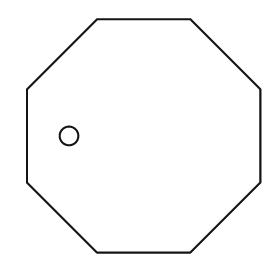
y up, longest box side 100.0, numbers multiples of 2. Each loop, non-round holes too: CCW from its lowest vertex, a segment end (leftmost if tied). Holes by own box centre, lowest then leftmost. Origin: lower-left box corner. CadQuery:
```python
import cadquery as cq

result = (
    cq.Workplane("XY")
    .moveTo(30.0, 0.0)
    .lineTo(70.0, 0.0)
    .lineTo(100.0, 30.0)
    .lineTo(100.0, 70.0)
    .lineTo(70.0, 100.0)
    .lineTo(30.0, 100.0)
    .lineTo(0.0, 70.0)
    .lineTo(0.0, 30.0)
    .close()
    .moveTo(18.0, 50.0)
    .circle(4.0)
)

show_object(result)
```